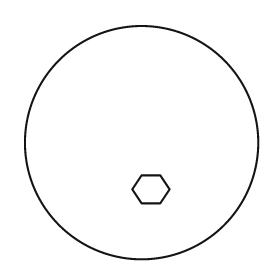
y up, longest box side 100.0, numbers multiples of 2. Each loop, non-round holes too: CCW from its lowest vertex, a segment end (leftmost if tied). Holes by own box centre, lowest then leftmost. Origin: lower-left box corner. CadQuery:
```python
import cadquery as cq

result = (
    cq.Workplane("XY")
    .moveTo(50.0, 50.0)
    .circle(50.0)
    .moveTo(50.0, 24.0)
    .lineTo(58.0, 24.0)
    .lineTo(62.0, 30.0)
    .lineTo(58.0, 36.0)
    .lineTo(50.0, 36.0)
    .lineTo(46.0, 30.0)
    .close()
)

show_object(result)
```